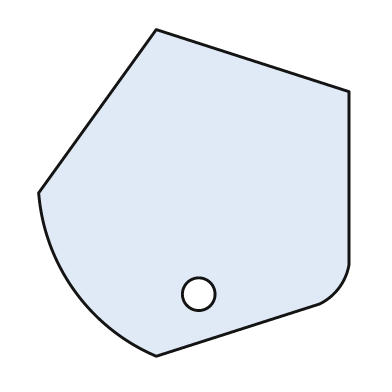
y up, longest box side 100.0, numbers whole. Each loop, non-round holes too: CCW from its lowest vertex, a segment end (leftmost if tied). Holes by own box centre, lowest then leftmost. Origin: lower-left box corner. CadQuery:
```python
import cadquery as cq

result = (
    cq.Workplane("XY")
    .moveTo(36.0, 0.0)
    .lineTo(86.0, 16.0)
    .threePointArc((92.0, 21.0), (95.0, 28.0))
    .lineTo(95.0, 81.0)
    .lineTo(36.0, 100.0)
    .lineTo(0.0, 50.0)
    .threePointArc((11.0, 20.0), (36.0, 0.0))
    .close()
    .moveTo(49.0, 19.0)
    .circle(5.0)
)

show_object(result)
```